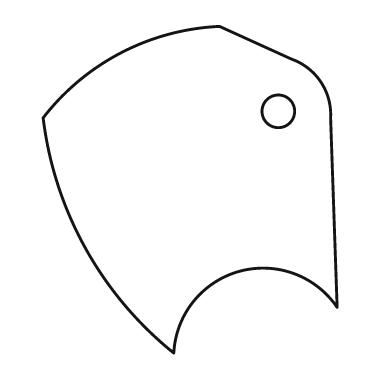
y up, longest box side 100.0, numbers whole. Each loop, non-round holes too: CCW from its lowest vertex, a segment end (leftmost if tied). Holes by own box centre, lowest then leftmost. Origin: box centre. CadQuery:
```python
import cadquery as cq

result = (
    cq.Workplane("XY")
    .moveTo(-5.0, -50.0)
    .threePointArc((15.0, -25.0), (45.0, -36.0))
    .lineTo(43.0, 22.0)
    .threePointArc((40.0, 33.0), (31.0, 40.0))
    .lineTo(9.0, 50.0)
    .threePointArc((-21.0, 42.0), (-45.0, 22.0))
    .threePointArc((-32.0, -18.0), (-5.0, -50.0))
    .close()
    .moveTo(27.0, 24.0)
    .circle(5.0)
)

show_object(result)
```